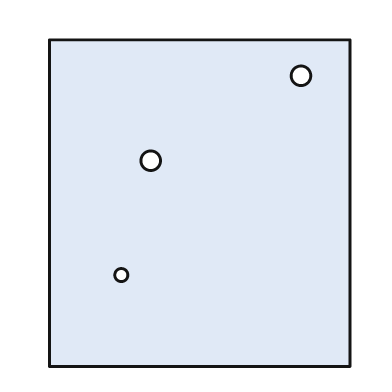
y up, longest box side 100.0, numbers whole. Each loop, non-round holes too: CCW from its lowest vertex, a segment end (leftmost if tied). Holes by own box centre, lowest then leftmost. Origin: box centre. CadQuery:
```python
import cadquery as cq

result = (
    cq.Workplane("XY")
    .moveTo(-46.0, -50.0)
    .lineTo(46.0, -50.0)
    .lineTo(46.0, 50.0)
    .lineTo(-46.0, 50.0)
    .close()
    .moveTo(-24.0, -22.0)
    .circle(2.0)
    .moveTo(-15.0, 13.0)
    .circle(3.0)
    .moveTo(31.0, 39.0)
    .circle(3.0)
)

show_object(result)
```